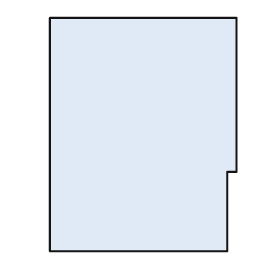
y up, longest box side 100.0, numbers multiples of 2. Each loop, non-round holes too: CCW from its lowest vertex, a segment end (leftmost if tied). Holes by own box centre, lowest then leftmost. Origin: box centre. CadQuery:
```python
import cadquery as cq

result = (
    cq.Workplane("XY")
    .moveTo(-40.0, -50.0)
    .lineTo(36.0, -50.0)
    .lineTo(36.0, -16.0)
    .lineTo(40.0, -16.0)
    .lineTo(40.0, 50.0)
    .lineTo(-40.0, 50.0)
    .close()
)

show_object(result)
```